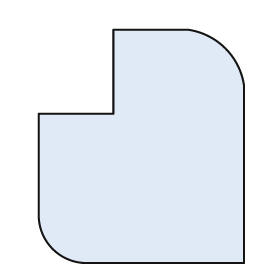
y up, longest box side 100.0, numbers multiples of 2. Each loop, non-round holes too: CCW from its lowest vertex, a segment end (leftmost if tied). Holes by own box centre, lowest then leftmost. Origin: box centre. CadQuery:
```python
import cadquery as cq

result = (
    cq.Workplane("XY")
    .moveTo(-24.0, -50.0)
    .lineTo(44.0, -50.0)
    .lineTo(44.0, 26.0)
    .threePointArc((36.0, 42.0), (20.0, 50.0))
    .lineTo(-12.0, 50.0)
    .lineTo(-12.0, 14.0)
    .lineTo(-44.0, 14.0)
    .lineTo(-44.0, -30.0)
    .threePointArc((-38.0, -44.0), (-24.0, -50.0))
    .close()
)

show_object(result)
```